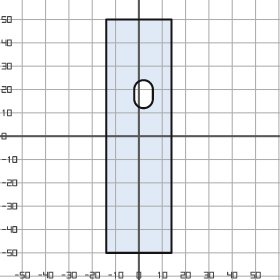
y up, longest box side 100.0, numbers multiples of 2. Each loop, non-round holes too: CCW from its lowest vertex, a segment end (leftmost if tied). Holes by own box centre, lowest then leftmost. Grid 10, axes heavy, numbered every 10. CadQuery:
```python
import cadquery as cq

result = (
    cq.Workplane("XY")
    .moveTo(-14.0, -50.0)
    .lineTo(14.0, -50.0)
    .lineTo(14.0, 50.0)
    .lineTo(-14.0, 50.0)
    .close()
    .moveTo(-2.0, 16.0)
    .threePointArc((2.0, 12.0), (6.0, 16.0))
    .lineTo(6.0, 20.0)
    .threePointArc((2.0, 24.0), (-2.0, 20.0))
    .close()
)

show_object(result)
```